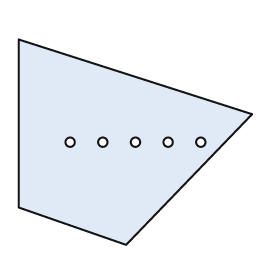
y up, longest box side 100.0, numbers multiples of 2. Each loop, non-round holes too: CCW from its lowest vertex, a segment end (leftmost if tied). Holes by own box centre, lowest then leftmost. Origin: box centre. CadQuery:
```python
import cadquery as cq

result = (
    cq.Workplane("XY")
    .moveTo(-4.0, -44.0)
    .lineTo(50.0, 12.0)
    .lineTo(-50.0, 44.0)
    .lineTo(-50.0, -28.0)
    .close()
    .moveTo(-28.0, 0.0)
    .circle(2.0)
    .moveTo(-14.0, 0.0)
    .circle(2.0)
    .moveTo(0.0, 0.0)
    .circle(2.0)
    .moveTo(14.0, 0.0)
    .circle(2.0)
    .moveTo(28.0, 0.0)
    .circle(2.0)
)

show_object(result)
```